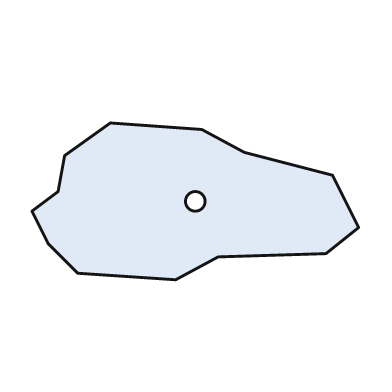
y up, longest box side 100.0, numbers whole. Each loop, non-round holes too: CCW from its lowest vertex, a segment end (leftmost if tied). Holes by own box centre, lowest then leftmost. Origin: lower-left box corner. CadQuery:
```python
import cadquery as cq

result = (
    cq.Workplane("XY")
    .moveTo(44.0, 0.0)
    .lineTo(57.0, 7.0)
    .lineTo(90.0, 8.0)
    .lineTo(100.0, 16.0)
    .lineTo(92.0, 32.0)
    .lineTo(65.0, 39.0)
    .lineTo(52.0, 46.0)
    .lineTo(24.0, 48.0)
    .lineTo(10.0, 38.0)
    .lineTo(8.0, 27.0)
    .lineTo(0.0, 21.0)
    .lineTo(5.0, 11.0)
    .lineTo(14.0, 2.0)
    .close()
    .moveTo(50.0, 24.0)
    .circle(3.0)
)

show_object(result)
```